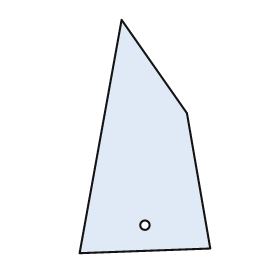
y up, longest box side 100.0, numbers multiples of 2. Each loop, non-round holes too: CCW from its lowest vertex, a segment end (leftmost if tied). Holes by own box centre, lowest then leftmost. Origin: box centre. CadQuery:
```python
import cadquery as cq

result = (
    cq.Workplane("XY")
    .moveTo(-28.0, -50.0)
    .lineTo(28.0, -48.0)
    .lineTo(18.0, 10.0)
    .lineTo(-10.0, 50.0)
    .close()
    .moveTo(0.0, -38.0)
    .circle(2.0)
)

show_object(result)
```